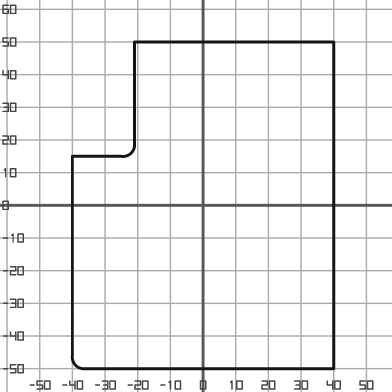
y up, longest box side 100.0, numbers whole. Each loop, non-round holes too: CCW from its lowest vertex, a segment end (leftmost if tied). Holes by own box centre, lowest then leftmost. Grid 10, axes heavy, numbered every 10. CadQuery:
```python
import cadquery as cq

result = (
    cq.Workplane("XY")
    .moveTo(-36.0, -50.0)
    .lineTo(40.0, -50.0)
    .lineTo(40.0, 50.0)
    .lineTo(-21.0, 50.0)
    .lineTo(-21.0, 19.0)
    .threePointArc((-22.0, 16.0), (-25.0, 15.0))
    .lineTo(-40.0, 15.0)
    .lineTo(-40.0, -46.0)
    .threePointArc((-39.0, -49.0), (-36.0, -50.0))
    .close()
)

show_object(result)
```